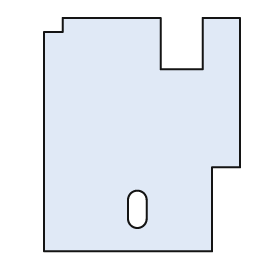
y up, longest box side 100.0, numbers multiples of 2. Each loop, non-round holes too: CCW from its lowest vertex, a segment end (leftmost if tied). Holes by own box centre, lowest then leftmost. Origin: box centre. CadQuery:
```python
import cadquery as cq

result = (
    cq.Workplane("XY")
    .moveTo(-42.0, -50.0)
    .lineTo(30.0, -50.0)
    .lineTo(30.0, -14.0)
    .lineTo(42.0, -14.0)
    .lineTo(42.0, 50.0)
    .lineTo(26.0, 50.0)
    .lineTo(26.0, 28.0)
    .lineTo(8.0, 28.0)
    .lineTo(8.0, 50.0)
    .lineTo(-34.0, 50.0)
    .lineTo(-34.0, 44.0)
    .lineTo(-42.0, 44.0)
    .close()
    .moveTo(-6.0, -36.0)
    .threePointArc((-2.0, -40.0), (2.0, -36.0))
    .lineTo(2.0, -28.0)
    .threePointArc((-2.0, -24.0), (-6.0, -28.0))
    .close()
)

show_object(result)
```